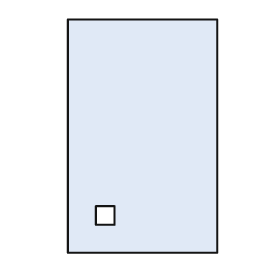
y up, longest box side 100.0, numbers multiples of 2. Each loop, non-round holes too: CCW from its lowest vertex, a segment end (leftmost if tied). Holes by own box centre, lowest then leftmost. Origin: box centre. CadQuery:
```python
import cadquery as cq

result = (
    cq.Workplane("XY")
    .moveTo(-32.0, -50.0)
    .lineTo(32.0, -50.0)
    .lineTo(32.0, 50.0)
    .lineTo(-32.0, 50.0)
    .close()
    .moveTo(-20.0, -38.0)
    .lineTo(-12.0, -38.0)
    .lineTo(-12.0, -30.0)
    .lineTo(-20.0, -30.0)
    .close()
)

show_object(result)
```